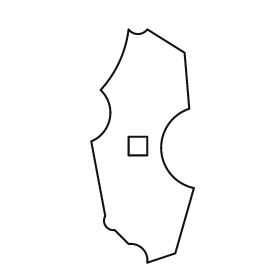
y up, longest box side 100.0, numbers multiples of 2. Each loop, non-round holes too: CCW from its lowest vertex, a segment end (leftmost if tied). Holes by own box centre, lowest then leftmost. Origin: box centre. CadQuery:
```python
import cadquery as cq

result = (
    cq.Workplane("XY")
    .moveTo(2.0, -50.0)
    .lineTo(14.0, -46.0)
    .lineTo(22.0, -18.0)
    .threePointArc((8.0, -2.0), (20.0, 16.0))
    .lineTo(18.0, 40.0)
    .lineTo(2.0, 50.0)
    .threePointArc((-2.0, 48.0), (-6.0, 50.0))
    .threePointArc((-10.0, 36.0), (-18.0, 24.0))
    .threePointArc((-14.0, 12.0), (-22.0, 2.0))
    .lineTo(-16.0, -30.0)
    .threePointArc((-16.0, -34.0), (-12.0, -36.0))
    .lineTo(-6.0, -42.0)
    .threePointArc((0.0, -44.0), (2.0, -50.0))
    .close()
    .moveTo(-6.0, -4.0)
    .lineTo(2.0, -4.0)
    .lineTo(2.0, 4.0)
    .lineTo(-6.0, 4.0)
    .close()
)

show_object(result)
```